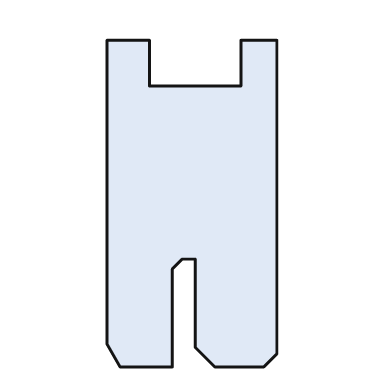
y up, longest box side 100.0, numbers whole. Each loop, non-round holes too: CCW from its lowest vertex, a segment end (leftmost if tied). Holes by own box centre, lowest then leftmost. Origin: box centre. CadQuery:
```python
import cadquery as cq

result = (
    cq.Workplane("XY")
    .moveTo(-22.0, -50.0)
    .lineTo(-6.0, -50.0)
    .lineTo(-6.0, -20.0)
    .lineTo(-3.0, -17.0)
    .lineTo(1.0, -17.0)
    .lineTo(1.0, -44.0)
    .lineTo(7.0, -50.0)
    .lineTo(22.0, -50.0)
    .lineTo(26.0, -46.0)
    .lineTo(26.0, 50.0)
    .lineTo(15.0, 50.0)
    .lineTo(15.0, 36.0)
    .lineTo(-13.0, 36.0)
    .lineTo(-13.0, 50.0)
    .lineTo(-26.0, 50.0)
    .lineTo(-26.0, -43.0)
    .close()
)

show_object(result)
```